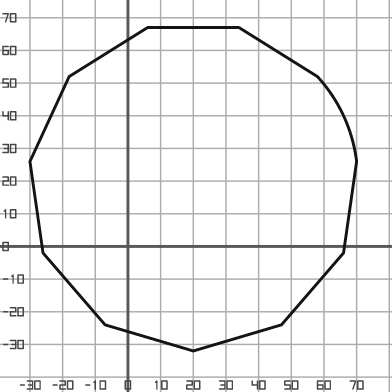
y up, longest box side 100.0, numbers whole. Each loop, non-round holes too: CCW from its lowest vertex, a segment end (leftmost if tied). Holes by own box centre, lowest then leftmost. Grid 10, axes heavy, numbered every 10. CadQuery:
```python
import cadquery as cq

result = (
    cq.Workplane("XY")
    .moveTo(20.0, -32.0)
    .lineTo(47.0, -24.0)
    .lineTo(66.0, -2.0)
    .lineTo(70.0, 26.0)
    .threePointArc((66.0, 40.0), (58.0, 52.0))
    .lineTo(34.0, 67.0)
    .lineTo(6.0, 67.0)
    .lineTo(-18.0, 52.0)
    .lineTo(-30.0, 26.0)
    .lineTo(-26.0, -2.0)
    .lineTo(-7.0, -24.0)
    .close()
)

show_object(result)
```